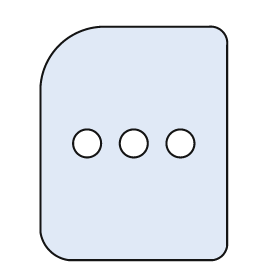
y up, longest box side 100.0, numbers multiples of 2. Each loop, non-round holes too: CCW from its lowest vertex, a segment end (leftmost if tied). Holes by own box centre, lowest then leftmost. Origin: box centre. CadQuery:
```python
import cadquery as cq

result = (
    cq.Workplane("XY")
    .moveTo(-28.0, -50.0)
    .lineTo(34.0, -50.0)
    .threePointArc((38.0, -48.0), (40.0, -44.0))
    .lineTo(40.0, 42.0)
    .threePointArc((38.0, 48.0), (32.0, 50.0))
    .lineTo(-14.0, 50.0)
    .threePointArc((-32.0, 42.0), (-40.0, 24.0))
    .lineTo(-40.0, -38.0)
    .threePointArc((-36.0, -46.0), (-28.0, -50.0))
    .close()
    .moveTo(-20.0, 0.0)
    .circle(6.0)
    .moveTo(0.0, 0.0)
    .circle(6.0)
    .moveTo(20.0, 0.0)
    .circle(6.0)
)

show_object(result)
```